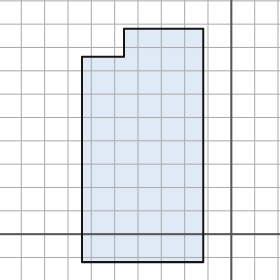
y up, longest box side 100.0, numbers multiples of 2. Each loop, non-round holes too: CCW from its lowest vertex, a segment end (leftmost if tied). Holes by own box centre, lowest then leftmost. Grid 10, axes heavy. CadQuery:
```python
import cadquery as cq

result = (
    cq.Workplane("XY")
    .moveTo(-64.0, -12.0)
    .lineTo(-12.0, -12.0)
    .lineTo(-12.0, 88.0)
    .lineTo(-46.0, 88.0)
    .lineTo(-46.0, 76.0)
    .lineTo(-64.0, 76.0)
    .close()
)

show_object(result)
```